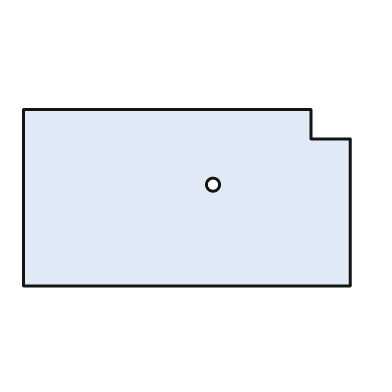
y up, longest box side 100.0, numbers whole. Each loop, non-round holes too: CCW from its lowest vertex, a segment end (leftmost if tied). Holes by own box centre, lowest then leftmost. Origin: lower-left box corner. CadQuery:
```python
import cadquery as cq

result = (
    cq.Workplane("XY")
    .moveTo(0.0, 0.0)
    .lineTo(100.0, 0.0)
    .lineTo(100.0, 45.0)
    .lineTo(88.0, 45.0)
    .lineTo(88.0, 54.0)
    .lineTo(0.0, 54.0)
    .close()
    .moveTo(58.0, 31.0)
    .circle(2.0)
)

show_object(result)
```